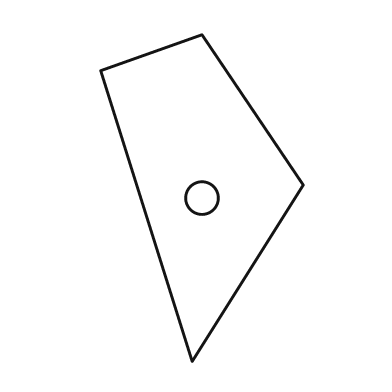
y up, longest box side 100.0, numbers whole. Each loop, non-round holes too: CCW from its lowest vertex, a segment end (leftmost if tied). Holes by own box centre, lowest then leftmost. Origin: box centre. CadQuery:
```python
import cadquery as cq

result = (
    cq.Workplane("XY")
    .moveTo(-3.0, -50.0)
    .lineTo(31.0, 4.0)
    .lineTo(0.0, 50.0)
    .lineTo(-31.0, 39.0)
    .close()
    .moveTo(0.0, 0.0)
    .circle(5.0)
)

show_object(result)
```